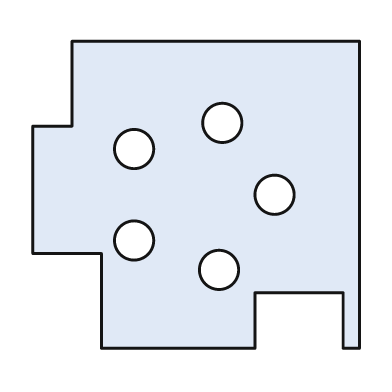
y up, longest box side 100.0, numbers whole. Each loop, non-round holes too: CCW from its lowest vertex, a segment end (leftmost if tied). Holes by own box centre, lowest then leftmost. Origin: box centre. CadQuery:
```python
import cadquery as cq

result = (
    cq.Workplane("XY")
    .moveTo(-29.0, -47.0)
    .lineTo(18.0, -47.0)
    .lineTo(18.0, -30.0)
    .lineTo(45.0, -30.0)
    .lineTo(45.0, -47.0)
    .lineTo(50.0, -47.0)
    .lineTo(50.0, 47.0)
    .lineTo(-38.0, 47.0)
    .lineTo(-38.0, 21.0)
    .lineTo(-50.0, 21.0)
    .lineTo(-50.0, -18.0)
    .lineTo(-29.0, -18.0)
    .close()
    .moveTo(7.0, -23.0)
    .circle(6.0)
    .moveTo(-19.0, -14.0)
    .circle(6.0)
    .moveTo(24.0, 0.0)
    .circle(6.0)
    .moveTo(-19.0, 14.0)
    .circle(6.0)
    .moveTo(8.0, 22.0)
    .circle(6.0)
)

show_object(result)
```